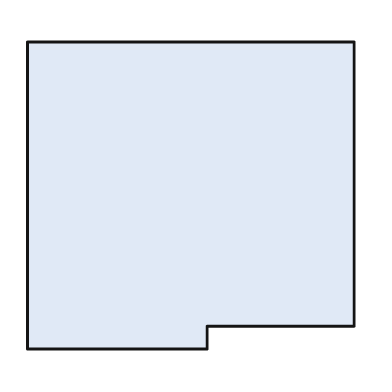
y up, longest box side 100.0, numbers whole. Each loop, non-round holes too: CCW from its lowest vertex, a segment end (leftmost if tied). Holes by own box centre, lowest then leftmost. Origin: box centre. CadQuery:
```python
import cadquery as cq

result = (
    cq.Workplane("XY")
    .moveTo(-50.0, -47.0)
    .lineTo(5.0, -47.0)
    .lineTo(5.0, -40.0)
    .lineTo(50.0, -40.0)
    .lineTo(50.0, 47.0)
    .lineTo(-50.0, 47.0)
    .close()
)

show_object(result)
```